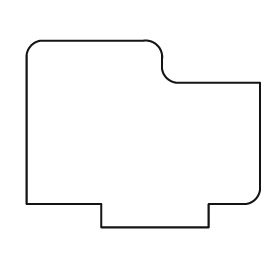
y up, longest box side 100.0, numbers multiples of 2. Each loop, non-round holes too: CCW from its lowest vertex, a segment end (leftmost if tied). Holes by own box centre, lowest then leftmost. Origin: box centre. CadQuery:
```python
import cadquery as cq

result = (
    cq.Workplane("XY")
    .moveTo(-18.0, -40.0)
    .lineTo(28.0, -40.0)
    .lineTo(28.0, -30.0)
    .lineTo(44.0, -30.0)
    .threePointArc((48.0, -28.0), (50.0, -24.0))
    .lineTo(50.0, 22.0)
    .lineTo(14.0, 22.0)
    .threePointArc((10.0, 24.0), (8.0, 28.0))
    .lineTo(8.0, 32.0)
    .threePointArc((6.0, 38.0), (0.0, 40.0))
    .lineTo(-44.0, 40.0)
    .threePointArc((-48.0, 38.0), (-50.0, 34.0))
    .lineTo(-50.0, -30.0)
    .lineTo(-18.0, -30.0)
    .close()
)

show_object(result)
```